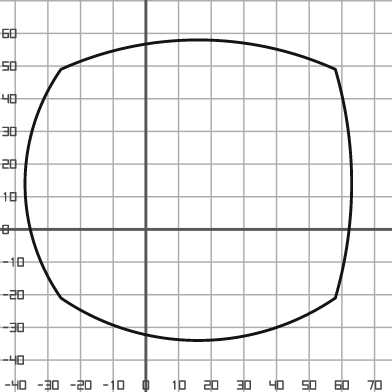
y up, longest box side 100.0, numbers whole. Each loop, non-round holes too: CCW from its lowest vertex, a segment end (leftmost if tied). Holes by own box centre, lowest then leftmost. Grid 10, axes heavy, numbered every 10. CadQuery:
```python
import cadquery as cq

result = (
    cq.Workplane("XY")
    .moveTo(-26.0, -21.0)
    .threePointArc((16.0, -34.0), (58.0, -21.0))
    .threePointArc((63.0, 14.0), (58.0, 49.0))
    .threePointArc((16.0, 58.0), (-26.0, 49.0))
    .threePointArc((-37.0, 14.0), (-26.0, -21.0))
    .close()
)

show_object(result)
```